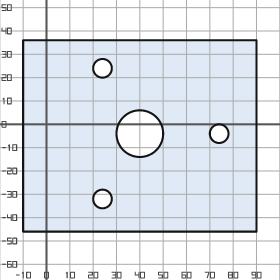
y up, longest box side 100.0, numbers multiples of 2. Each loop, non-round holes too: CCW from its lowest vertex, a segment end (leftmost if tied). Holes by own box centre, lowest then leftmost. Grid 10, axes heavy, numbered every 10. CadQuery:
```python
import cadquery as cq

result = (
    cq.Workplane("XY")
    .moveTo(-10.0, -46.0)
    .lineTo(90.0, -46.0)
    .lineTo(90.0, 36.0)
    .lineTo(-10.0, 36.0)
    .close()
    .moveTo(24.0, -32.0)
    .circle(4.0)
    .moveTo(40.0, -4.0)
    .circle(10.0)
    .moveTo(74.0, -4.0)
    .circle(4.0)
    .moveTo(24.0, 24.0)
    .circle(4.0)
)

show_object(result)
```